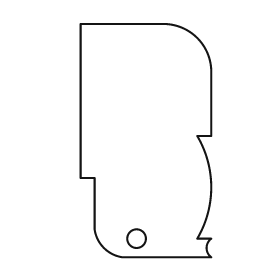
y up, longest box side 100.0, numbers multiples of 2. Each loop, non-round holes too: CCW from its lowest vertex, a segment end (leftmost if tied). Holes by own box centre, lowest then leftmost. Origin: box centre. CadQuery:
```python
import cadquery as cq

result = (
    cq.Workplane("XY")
    .moveTo(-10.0, -50.0)
    .lineTo(28.0, -50.0)
    .threePointArc((26.0, -46.0), (28.0, -42.0))
    .lineTo(22.0, -42.0)
    .threePointArc((28.0, -20.0), (22.0, 2.0))
    .lineTo(28.0, 2.0)
    .lineTo(28.0, 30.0)
    .threePointArc((22.0, 44.0), (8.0, 50.0))
    .lineTo(-28.0, 50.0)
    .lineTo(-28.0, -16.0)
    .lineTo(-22.0, -16.0)
    .lineTo(-22.0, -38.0)
    .threePointArc((-18.0, -46.0), (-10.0, -50.0))
    .close()
    .moveTo(-4.0, -42.0)
    .circle(4.0)
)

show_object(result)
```